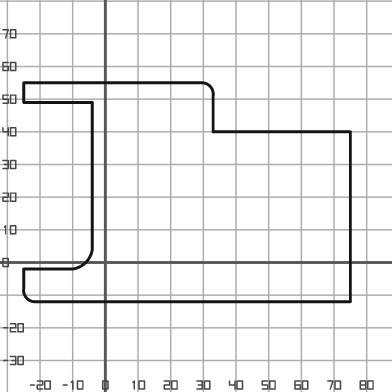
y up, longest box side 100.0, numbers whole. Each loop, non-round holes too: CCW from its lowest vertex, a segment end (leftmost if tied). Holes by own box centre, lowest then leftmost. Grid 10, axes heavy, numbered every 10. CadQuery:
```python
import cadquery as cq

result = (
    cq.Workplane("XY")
    .moveTo(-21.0, -12.0)
    .lineTo(75.0, -12.0)
    .lineTo(75.0, 40.0)
    .lineTo(33.0, 40.0)
    .lineTo(33.0, 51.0)
    .threePointArc((32.0, 54.0), (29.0, 55.0))
    .lineTo(-25.0, 55.0)
    .lineTo(-25.0, 49.0)
    .lineTo(-4.0, 49.0)
    .lineTo(-4.0, 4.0)
    .threePointArc((-6.0, 0.0), (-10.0, -2.0))
    .lineTo(-25.0, -2.0)
    .lineTo(-25.0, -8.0)
    .threePointArc((-24.0, -11.0), (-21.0, -12.0))
    .close()
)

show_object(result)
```